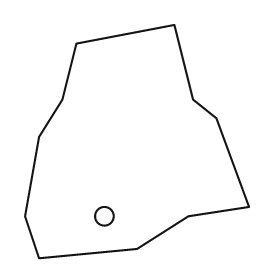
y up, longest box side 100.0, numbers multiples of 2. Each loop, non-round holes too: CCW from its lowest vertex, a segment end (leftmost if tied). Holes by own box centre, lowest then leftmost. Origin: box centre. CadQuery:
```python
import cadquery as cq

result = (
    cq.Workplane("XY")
    .moveTo(-42.0, -50.0)
    .lineTo(0.0, -46.0)
    .lineTo(22.0, -32.0)
    .lineTo(48.0, -28.0)
    .lineTo(34.0, 10.0)
    .lineTo(24.0, 18.0)
    .lineTo(16.0, 50.0)
    .lineTo(-26.0, 42.0)
    .lineTo(-32.0, 18.0)
    .lineTo(-42.0, 2.0)
    .lineTo(-48.0, -32.0)
    .close()
    .moveTo(-14.0, -32.0)
    .circle(4.0)
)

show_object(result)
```